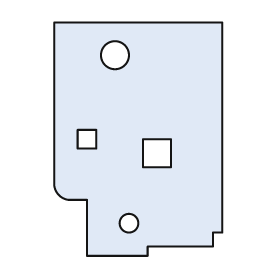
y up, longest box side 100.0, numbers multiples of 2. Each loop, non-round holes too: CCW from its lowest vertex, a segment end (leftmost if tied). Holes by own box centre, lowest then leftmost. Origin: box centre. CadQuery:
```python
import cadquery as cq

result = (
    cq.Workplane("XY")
    .moveTo(-22.0, -50.0)
    .lineTo(4.0, -50.0)
    .lineTo(4.0, -46.0)
    .lineTo(32.0, -46.0)
    .lineTo(32.0, -40.0)
    .lineTo(36.0, -40.0)
    .lineTo(36.0, 50.0)
    .lineTo(-36.0, 50.0)
    .lineTo(-36.0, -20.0)
    .threePointArc((-34.0, -24.0), (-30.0, -26.0))
    .lineTo(-22.0, -26.0)
    .close()
    .moveTo(-4.0, -36.0)
    .circle(4.0)
    .moveTo(2.0, -12.0)
    .lineTo(14.0, -12.0)
    .lineTo(14.0, 0.0)
    .lineTo(2.0, 0.0)
    .close()
    .moveTo(-26.0, -4.0)
    .lineTo(-18.0, -4.0)
    .lineTo(-18.0, 4.0)
    .lineTo(-26.0, 4.0)
    .close()
    .moveTo(-10.0, 36.0)
    .circle(6.0)
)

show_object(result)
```